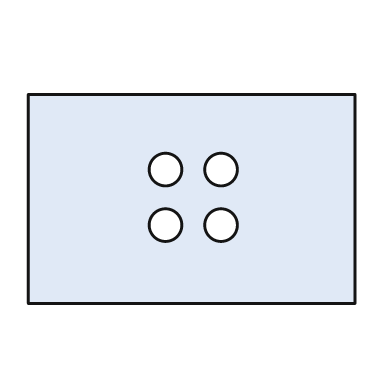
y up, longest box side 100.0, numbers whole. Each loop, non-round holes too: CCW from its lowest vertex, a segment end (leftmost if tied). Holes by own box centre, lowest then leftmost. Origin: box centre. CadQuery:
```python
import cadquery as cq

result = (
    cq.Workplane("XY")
    .moveTo(-50.0, -32.0)
    .lineTo(50.0, -32.0)
    .lineTo(50.0, 32.0)
    .lineTo(-50.0, 32.0)
    .close()
    .moveTo(-8.0, -8.0)
    .circle(5.0)
    .moveTo(9.0, -8.0)
    .circle(5.0)
    .moveTo(-8.0, 9.0)
    .circle(5.0)
    .moveTo(9.0, 9.0)
    .circle(5.0)
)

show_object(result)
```